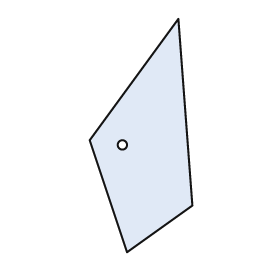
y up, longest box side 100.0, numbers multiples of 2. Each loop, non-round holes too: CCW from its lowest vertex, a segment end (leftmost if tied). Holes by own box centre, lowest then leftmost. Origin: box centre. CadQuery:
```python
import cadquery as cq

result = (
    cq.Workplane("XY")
    .moveTo(-6.0, -50.0)
    .lineTo(22.0, -30.0)
    .lineTo(16.0, 50.0)
    .lineTo(-22.0, -2.0)
    .close()
    .moveTo(-8.0, -4.0)
    .circle(2.0)
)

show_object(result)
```